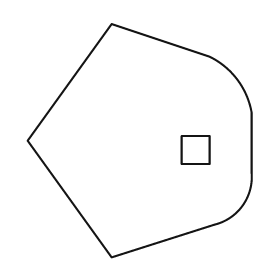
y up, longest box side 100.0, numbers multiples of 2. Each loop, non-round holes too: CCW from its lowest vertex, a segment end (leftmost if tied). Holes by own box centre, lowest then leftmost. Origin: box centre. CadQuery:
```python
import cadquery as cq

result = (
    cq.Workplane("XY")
    .moveTo(-12.0, -50.0)
    .lineTo(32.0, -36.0)
    .threePointArc((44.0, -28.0), (48.0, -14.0))
    .lineTo(48.0, 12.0)
    .threePointArc((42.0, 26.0), (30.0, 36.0))
    .lineTo(-12.0, 50.0)
    .lineTo(-48.0, 0.0)
    .close()
    .moveTo(18.0, -10.0)
    .lineTo(30.0, -10.0)
    .lineTo(30.0, 2.0)
    .lineTo(18.0, 2.0)
    .close()
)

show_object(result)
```